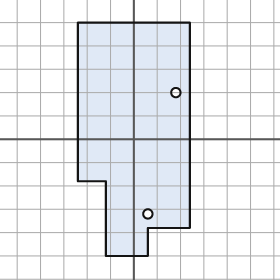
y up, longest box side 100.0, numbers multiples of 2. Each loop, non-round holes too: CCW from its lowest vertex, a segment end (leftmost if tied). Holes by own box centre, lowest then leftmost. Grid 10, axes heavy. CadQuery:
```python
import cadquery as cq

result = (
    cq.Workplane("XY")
    .moveTo(-12.0, -50.0)
    .lineTo(6.0, -50.0)
    .lineTo(6.0, -38.0)
    .lineTo(24.0, -38.0)
    .lineTo(24.0, 50.0)
    .lineTo(-24.0, 50.0)
    .lineTo(-24.0, -18.0)
    .lineTo(-12.0, -18.0)
    .close()
    .moveTo(6.0, -32.0)
    .circle(2.0)
    .moveTo(18.0, 20.0)
    .circle(2.0)
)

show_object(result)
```